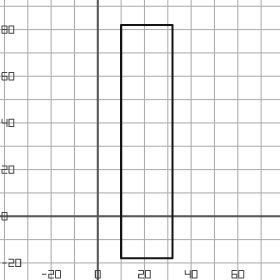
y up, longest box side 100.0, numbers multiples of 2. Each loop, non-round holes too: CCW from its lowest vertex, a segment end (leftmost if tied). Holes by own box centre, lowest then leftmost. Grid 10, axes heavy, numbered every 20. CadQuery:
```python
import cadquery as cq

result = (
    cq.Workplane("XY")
    .moveTo(10.0, -18.0)
    .lineTo(32.0, -18.0)
    .lineTo(32.0, 82.0)
    .lineTo(10.0, 82.0)
    .close()
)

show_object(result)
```